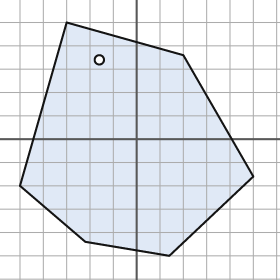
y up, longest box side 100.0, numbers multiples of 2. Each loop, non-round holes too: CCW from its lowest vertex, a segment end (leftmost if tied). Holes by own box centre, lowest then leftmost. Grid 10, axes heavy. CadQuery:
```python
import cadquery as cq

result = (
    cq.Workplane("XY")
    .moveTo(14.0, -50.0)
    .lineTo(50.0, -16.0)
    .lineTo(20.0, 36.0)
    .lineTo(-30.0, 50.0)
    .lineTo(-50.0, -20.0)
    .lineTo(-22.0, -44.0)
    .close()
    .moveTo(-16.0, 34.0)
    .circle(2.0)
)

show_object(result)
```